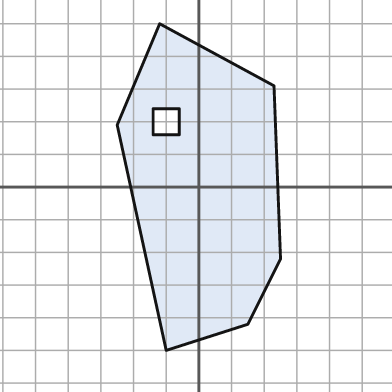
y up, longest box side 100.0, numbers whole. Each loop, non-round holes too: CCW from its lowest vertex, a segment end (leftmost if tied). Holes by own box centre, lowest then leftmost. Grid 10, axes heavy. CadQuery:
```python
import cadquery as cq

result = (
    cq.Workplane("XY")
    .moveTo(-10.0, -50.0)
    .lineTo(15.0, -42.0)
    .lineTo(25.0, -22.0)
    .lineTo(23.0, 31.0)
    .lineTo(-12.0, 50.0)
    .lineTo(-25.0, 19.0)
    .close()
    .moveTo(-14.0, 16.0)
    .lineTo(-6.0, 16.0)
    .lineTo(-6.0, 24.0)
    .lineTo(-14.0, 24.0)
    .close()
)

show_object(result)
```